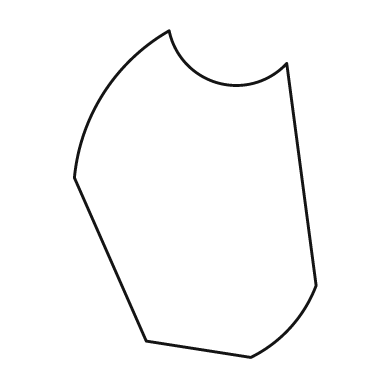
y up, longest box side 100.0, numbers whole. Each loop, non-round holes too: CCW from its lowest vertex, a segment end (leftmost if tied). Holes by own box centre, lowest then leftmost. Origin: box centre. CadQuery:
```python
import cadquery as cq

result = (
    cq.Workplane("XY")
    .moveTo(17.0, -50.0)
    .threePointArc((29.0, -41.0), (37.0, -28.0))
    .lineTo(28.0, 40.0)
    .threePointArc((7.0, 34.0), (-8.0, 50.0))
    .threePointArc((-28.0, 31.0), (-37.0, 5.0))
    .lineTo(-15.0, -45.0)
    .close()
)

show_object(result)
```